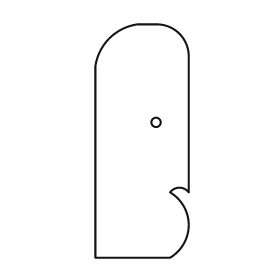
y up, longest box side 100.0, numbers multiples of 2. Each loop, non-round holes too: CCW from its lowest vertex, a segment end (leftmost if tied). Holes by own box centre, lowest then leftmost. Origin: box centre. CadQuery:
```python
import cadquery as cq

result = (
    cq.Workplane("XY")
    .moveTo(-20.0, -50.0)
    .lineTo(12.0, -50.0)
    .threePointArc((20.0, -36.0), (12.0, -22.0))
    .threePointArc((16.0, -20.0), (20.0, -22.0))
    .lineTo(20.0, 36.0)
    .threePointArc((16.0, 46.0), (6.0, 50.0))
    .lineTo(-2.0, 50.0)
    .threePointArc((-14.0, 44.0), (-20.0, 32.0))
    .close()
    .moveTo(6.0, 8.0)
    .circle(2.0)
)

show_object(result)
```